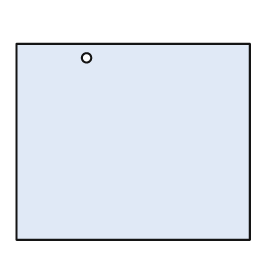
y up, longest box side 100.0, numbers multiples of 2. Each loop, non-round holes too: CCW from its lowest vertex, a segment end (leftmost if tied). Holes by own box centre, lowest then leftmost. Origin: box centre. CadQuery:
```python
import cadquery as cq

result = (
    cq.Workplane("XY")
    .moveTo(-50.0, -42.0)
    .lineTo(50.0, -42.0)
    .lineTo(50.0, 42.0)
    .lineTo(-50.0, 42.0)
    .close()
    .moveTo(-20.0, 36.0)
    .circle(2.0)
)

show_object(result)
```